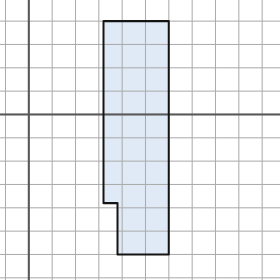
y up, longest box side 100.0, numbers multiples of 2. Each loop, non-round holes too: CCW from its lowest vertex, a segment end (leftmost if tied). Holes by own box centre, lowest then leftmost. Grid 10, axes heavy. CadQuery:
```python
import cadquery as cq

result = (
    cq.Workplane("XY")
    .moveTo(38.0, -60.0)
    .lineTo(60.0, -60.0)
    .lineTo(60.0, 40.0)
    .lineTo(32.0, 40.0)
    .lineTo(32.0, -38.0)
    .lineTo(38.0, -38.0)
    .close()
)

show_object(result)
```